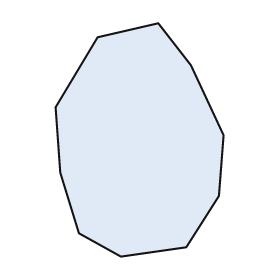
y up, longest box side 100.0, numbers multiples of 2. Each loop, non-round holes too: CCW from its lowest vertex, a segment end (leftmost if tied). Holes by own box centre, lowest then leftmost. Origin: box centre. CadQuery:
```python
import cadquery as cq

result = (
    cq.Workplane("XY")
    .moveTo(-8.0, -50.0)
    .lineTo(20.0, -46.0)
    .lineTo(34.0, -24.0)
    .lineTo(36.0, 2.0)
    .lineTo(22.0, 32.0)
    .lineTo(8.0, 50.0)
    .lineTo(-18.0, 44.0)
    .lineTo(-36.0, 14.0)
    .lineTo(-34.0, -14.0)
    .lineTo(-26.0, -40.0)
    .close()
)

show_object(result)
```